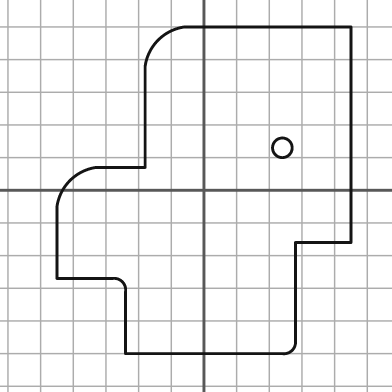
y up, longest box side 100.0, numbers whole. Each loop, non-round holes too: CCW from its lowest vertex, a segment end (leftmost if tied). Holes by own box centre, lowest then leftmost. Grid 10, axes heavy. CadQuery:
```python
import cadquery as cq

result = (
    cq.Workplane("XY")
    .moveTo(-24.0, -50.0)
    .lineTo(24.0, -50.0)
    .threePointArc((27.0, -49.0), (28.0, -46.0))
    .lineTo(28.0, -16.0)
    .lineTo(45.0, -16.0)
    .lineTo(45.0, 50.0)
    .lineTo(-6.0, 50.0)
    .threePointArc((-14.0, 46.0), (-18.0, 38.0))
    .lineTo(-18.0, 7.0)
    .lineTo(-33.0, 7.0)
    .threePointArc((-41.0, 3.0), (-45.0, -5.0))
    .lineTo(-45.0, -27.0)
    .lineTo(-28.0, -27.0)
    .threePointArc((-25.0, -28.0), (-24.0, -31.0))
    .close()
    .moveTo(24.0, 13.0)
    .circle(3.0)
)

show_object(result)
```